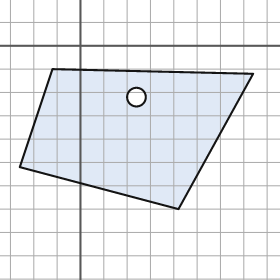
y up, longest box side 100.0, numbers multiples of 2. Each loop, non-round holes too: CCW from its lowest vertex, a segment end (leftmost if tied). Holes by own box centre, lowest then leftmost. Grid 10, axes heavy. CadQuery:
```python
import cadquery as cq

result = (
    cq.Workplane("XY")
    .moveTo(42.0, -70.0)
    .lineTo(74.0, -12.0)
    .lineTo(-12.0, -10.0)
    .lineTo(-26.0, -52.0)
    .close()
    .moveTo(24.0, -22.0)
    .circle(4.0)
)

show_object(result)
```